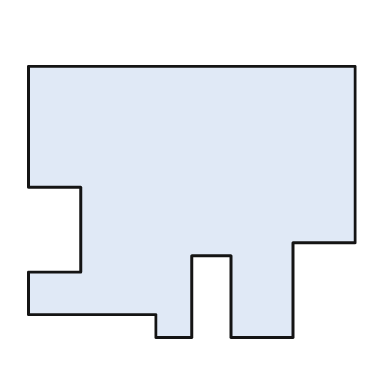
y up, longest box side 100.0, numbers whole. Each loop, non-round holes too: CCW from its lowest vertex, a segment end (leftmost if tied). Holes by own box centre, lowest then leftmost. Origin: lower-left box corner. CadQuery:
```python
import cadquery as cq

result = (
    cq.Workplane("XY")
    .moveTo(39.0, 0.0)
    .lineTo(50.0, 0.0)
    .lineTo(50.0, 25.0)
    .lineTo(62.0, 25.0)
    .lineTo(62.0, 0.0)
    .lineTo(81.0, 0.0)
    .lineTo(81.0, 29.0)
    .lineTo(100.0, 29.0)
    .lineTo(100.0, 83.0)
    .lineTo(0.0, 83.0)
    .lineTo(0.0, 46.0)
    .lineTo(16.0, 46.0)
    .lineTo(16.0, 20.0)
    .lineTo(0.0, 20.0)
    .lineTo(0.0, 7.0)
    .lineTo(39.0, 7.0)
    .close()
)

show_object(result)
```